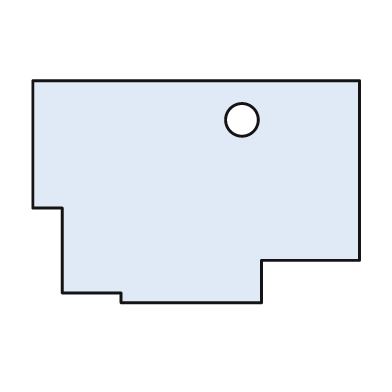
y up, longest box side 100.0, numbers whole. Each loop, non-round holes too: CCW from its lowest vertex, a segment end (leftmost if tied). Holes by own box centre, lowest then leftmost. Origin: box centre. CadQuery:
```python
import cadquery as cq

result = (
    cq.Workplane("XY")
    .moveTo(-23.0, -34.0)
    .lineTo(20.0, -34.0)
    .lineTo(20.0, -21.0)
    .lineTo(50.0, -21.0)
    .lineTo(50.0, 34.0)
    .lineTo(-50.0, 34.0)
    .lineTo(-50.0, -5.0)
    .lineTo(-41.0, -5.0)
    .lineTo(-41.0, -31.0)
    .lineTo(-23.0, -31.0)
    .close()
    .moveTo(14.0, 22.0)
    .circle(5.0)
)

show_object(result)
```